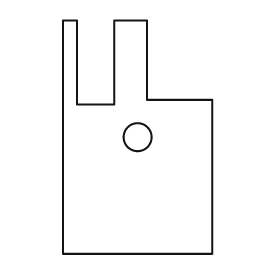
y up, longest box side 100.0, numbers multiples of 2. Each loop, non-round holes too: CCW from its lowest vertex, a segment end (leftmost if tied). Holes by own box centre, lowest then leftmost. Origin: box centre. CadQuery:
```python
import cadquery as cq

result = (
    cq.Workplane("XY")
    .moveTo(-32.0, -50.0)
    .lineTo(32.0, -50.0)
    .lineTo(32.0, 16.0)
    .lineTo(4.0, 16.0)
    .lineTo(4.0, 50.0)
    .lineTo(-10.0, 50.0)
    .lineTo(-10.0, 14.0)
    .lineTo(-26.0, 14.0)
    .lineTo(-26.0, 50.0)
    .lineTo(-32.0, 50.0)
    .close()
    .moveTo(0.0, 0.0)
    .circle(6.0)
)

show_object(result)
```